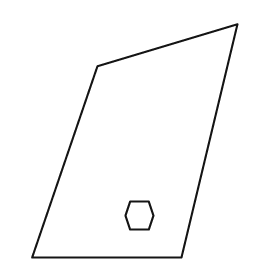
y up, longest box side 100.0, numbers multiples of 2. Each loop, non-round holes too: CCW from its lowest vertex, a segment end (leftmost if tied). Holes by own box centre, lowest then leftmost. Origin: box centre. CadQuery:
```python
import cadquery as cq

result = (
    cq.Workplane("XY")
    .moveTo(-44.0, -50.0)
    .lineTo(20.0, -50.0)
    .lineTo(44.0, 50.0)
    .lineTo(-16.0, 32.0)
    .close()
    .moveTo(-2.0, -38.0)
    .lineTo(6.0, -38.0)
    .lineTo(8.0, -32.0)
    .lineTo(6.0, -26.0)
    .lineTo(-2.0, -26.0)
    .lineTo(-4.0, -32.0)
    .close()
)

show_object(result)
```